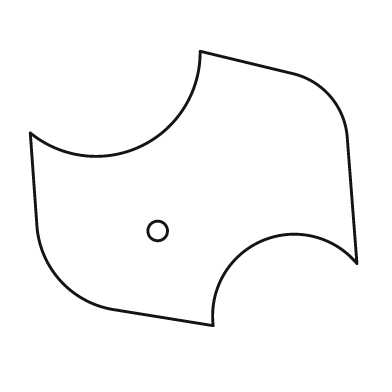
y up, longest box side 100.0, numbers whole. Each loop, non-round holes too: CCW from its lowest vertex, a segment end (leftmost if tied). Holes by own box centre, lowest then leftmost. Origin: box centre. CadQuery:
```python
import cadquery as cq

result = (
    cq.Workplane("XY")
    .moveTo(6.0, -42.0)
    .threePointArc((21.0, -16.0), (50.0, -23.0))
    .lineTo(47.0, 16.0)
    .threePointArc((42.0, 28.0), (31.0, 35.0))
    .lineTo(2.0, 42.0)
    .threePointArc((-16.0, 13.0), (-50.0, 17.0))
    .lineTo(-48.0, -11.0)
    .threePointArc((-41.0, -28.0), (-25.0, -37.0))
    .close()
    .moveTo(-11.0, -13.0)
    .circle(3.0)
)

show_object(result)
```